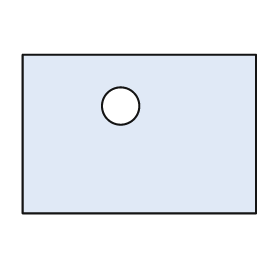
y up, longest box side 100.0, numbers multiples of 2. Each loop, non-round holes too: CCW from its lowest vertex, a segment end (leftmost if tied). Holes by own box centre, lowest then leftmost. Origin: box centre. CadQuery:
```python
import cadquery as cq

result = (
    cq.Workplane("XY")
    .moveTo(-50.0, -34.0)
    .lineTo(50.0, -34.0)
    .lineTo(50.0, 34.0)
    .lineTo(-50.0, 34.0)
    .close()
    .moveTo(-8.0, 12.0)
    .circle(8.0)
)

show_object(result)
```